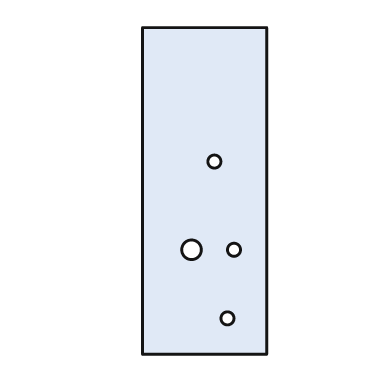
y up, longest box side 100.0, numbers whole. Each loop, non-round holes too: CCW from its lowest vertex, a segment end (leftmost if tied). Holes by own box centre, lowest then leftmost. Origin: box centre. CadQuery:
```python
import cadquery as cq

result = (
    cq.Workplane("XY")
    .moveTo(-19.0, -50.0)
    .lineTo(19.0, -50.0)
    .lineTo(19.0, 50.0)
    .lineTo(-19.0, 50.0)
    .close()
    .moveTo(7.0, -39.0)
    .circle(2.0)
    .moveTo(-4.0, -18.0)
    .circle(3.0)
    .moveTo(9.0, -18.0)
    .circle(2.0)
    .moveTo(3.0, 9.0)
    .circle(2.0)
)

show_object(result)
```